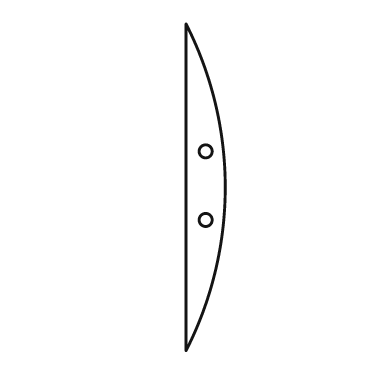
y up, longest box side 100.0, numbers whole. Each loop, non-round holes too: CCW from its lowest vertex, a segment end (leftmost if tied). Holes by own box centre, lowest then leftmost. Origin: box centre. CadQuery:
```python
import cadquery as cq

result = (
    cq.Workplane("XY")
    .moveTo(-6.0, -50.0)
    .threePointArc((6.0, 0.0), (-6.0, 50.0))
    .close()
    .moveTo(0.0, -10.0)
    .circle(2.0)
    .moveTo(0.0, 11.0)
    .circle(2.0)
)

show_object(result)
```